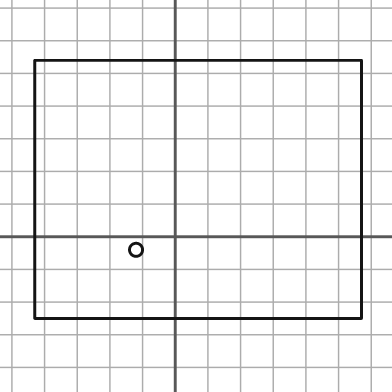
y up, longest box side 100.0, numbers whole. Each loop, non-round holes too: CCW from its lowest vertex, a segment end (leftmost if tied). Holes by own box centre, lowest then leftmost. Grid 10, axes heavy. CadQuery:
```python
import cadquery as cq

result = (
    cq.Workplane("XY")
    .moveTo(-43.0, -25.0)
    .lineTo(57.0, -25.0)
    .lineTo(57.0, 54.0)
    .lineTo(-43.0, 54.0)
    .close()
    .moveTo(-12.0, -4.0)
    .circle(2.0)
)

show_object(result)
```